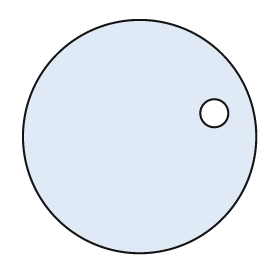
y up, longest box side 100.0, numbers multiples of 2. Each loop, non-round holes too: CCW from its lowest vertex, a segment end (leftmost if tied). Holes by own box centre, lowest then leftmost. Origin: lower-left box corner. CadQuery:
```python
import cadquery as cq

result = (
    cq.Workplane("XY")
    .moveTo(50.0, 50.0)
    .circle(50.0)
    .moveTo(82.0, 60.0)
    .circle(6.0)
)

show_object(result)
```